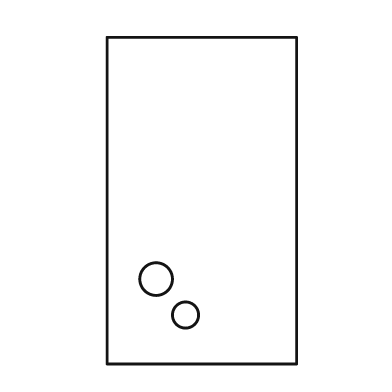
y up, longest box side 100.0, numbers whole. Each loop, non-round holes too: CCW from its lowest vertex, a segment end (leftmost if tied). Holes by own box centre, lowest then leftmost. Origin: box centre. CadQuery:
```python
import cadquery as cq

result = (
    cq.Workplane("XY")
    .moveTo(-29.0, -50.0)
    .lineTo(29.0, -50.0)
    .lineTo(29.0, 50.0)
    .lineTo(-29.0, 50.0)
    .close()
    .moveTo(-5.0, -35.0)
    .circle(4.0)
    .moveTo(-14.0, -24.0)
    .circle(5.0)
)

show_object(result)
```